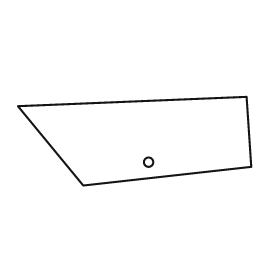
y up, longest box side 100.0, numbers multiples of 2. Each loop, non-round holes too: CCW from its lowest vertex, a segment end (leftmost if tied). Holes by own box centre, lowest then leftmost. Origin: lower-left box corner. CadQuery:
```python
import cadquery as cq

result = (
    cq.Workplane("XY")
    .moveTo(28.0, 0.0)
    .lineTo(100.0, 8.0)
    .lineTo(98.0, 38.0)
    .lineTo(0.0, 34.0)
    .close()
    .moveTo(56.0, 10.0)
    .circle(2.0)
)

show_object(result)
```